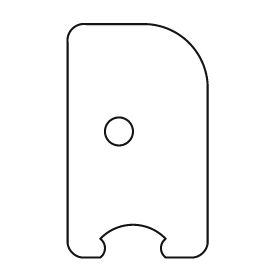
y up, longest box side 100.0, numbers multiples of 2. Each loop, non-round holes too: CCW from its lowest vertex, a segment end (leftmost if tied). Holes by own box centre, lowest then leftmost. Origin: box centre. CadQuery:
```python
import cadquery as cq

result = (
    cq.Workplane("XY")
    .moveTo(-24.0, -50.0)
    .lineTo(-16.0, -50.0)
    .threePointArc((-14.0, -46.0), (-16.0, -42.0))
    .threePointArc((-2.0, -36.0), (12.0, -42.0))
    .threePointArc((10.0, -46.0), (12.0, -50.0))
    .lineTo(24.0, -50.0)
    .threePointArc((28.0, -48.0), (30.0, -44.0))
    .lineTo(30.0, 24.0)
    .threePointArc((22.0, 42.0), (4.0, 50.0))
    .lineTo(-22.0, 50.0)
    .threePointArc((-28.0, 48.0), (-30.0, 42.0))
    .lineTo(-30.0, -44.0)
    .threePointArc((-28.0, -48.0), (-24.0, -50.0))
    .close()
    .moveTo(-8.0, 4.0)
    .circle(6.0)
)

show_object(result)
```